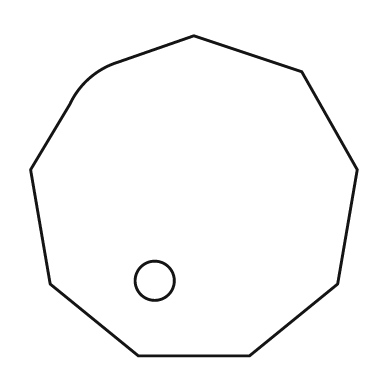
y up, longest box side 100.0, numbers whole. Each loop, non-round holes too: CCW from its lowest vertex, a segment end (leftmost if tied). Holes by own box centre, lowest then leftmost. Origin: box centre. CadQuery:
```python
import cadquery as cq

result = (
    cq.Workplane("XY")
    .moveTo(-17.0, -49.0)
    .lineTo(17.0, -49.0)
    .lineTo(44.0, -27.0)
    .lineTo(50.0, 8.0)
    .lineTo(33.0, 38.0)
    .lineTo(0.0, 49.0)
    .lineTo(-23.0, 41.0)
    .threePointArc((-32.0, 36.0), (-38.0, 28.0))
    .lineTo(-50.0, 8.0)
    .lineTo(-44.0, -27.0)
    .close()
    .moveTo(-12.0, -26.0)
    .circle(6.0)
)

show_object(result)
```